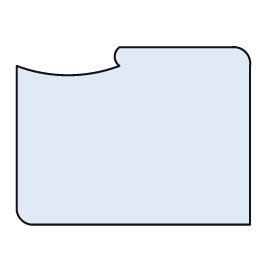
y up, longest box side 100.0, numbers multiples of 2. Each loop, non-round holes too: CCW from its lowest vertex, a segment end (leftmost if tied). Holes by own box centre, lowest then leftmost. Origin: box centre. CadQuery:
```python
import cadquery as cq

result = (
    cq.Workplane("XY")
    .moveTo(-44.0, -38.0)
    .lineTo(50.0, -38.0)
    .lineTo(50.0, 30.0)
    .threePointArc((48.0, 36.0), (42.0, 38.0))
    .lineTo(-6.0, 38.0)
    .threePointArc((-8.0, 34.0), (-6.0, 30.0))
    .threePointArc((-28.0, 26.0), (-50.0, 30.0))
    .lineTo(-50.0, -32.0)
    .threePointArc((-48.0, -36.0), (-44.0, -38.0))
    .close()
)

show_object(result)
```